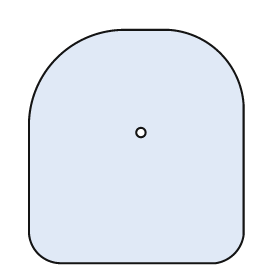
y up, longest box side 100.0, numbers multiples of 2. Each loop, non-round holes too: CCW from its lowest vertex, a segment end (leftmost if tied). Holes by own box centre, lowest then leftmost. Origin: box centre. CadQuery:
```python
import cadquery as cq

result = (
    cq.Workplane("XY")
    .moveTo(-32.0, -50.0)
    .lineTo(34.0, -50.0)
    .threePointArc((42.0, -46.0), (46.0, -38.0))
    .lineTo(46.0, 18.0)
    .threePointArc((36.0, 40.0), (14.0, 50.0))
    .lineTo(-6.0, 50.0)
    .threePointArc((-34.0, 38.0), (-46.0, 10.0))
    .lineTo(-46.0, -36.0)
    .threePointArc((-42.0, -46.0), (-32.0, -50.0))
    .close()
    .moveTo(2.0, 6.0)
    .circle(2.0)
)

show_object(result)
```